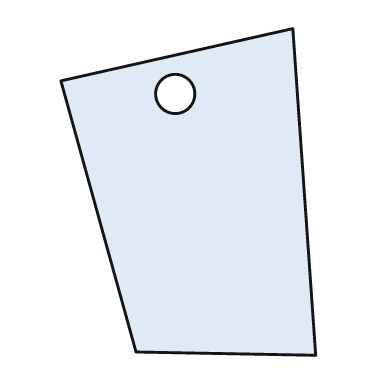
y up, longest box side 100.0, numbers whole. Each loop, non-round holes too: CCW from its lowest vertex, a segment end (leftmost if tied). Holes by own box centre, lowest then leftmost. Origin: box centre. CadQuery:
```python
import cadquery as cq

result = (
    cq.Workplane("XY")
    .moveTo(39.0, -50.0)
    .lineTo(32.0, 50.0)
    .lineTo(-39.0, 34.0)
    .lineTo(-16.0, -49.0)
    .close()
    .moveTo(-4.0, 30.0)
    .circle(6.0)
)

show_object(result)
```